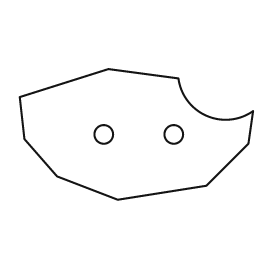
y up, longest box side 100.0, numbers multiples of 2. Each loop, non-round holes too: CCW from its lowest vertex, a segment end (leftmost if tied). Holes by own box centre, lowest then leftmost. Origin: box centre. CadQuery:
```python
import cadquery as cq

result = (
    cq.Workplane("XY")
    .moveTo(-8.0, -28.0)
    .lineTo(30.0, -22.0)
    .lineTo(48.0, -4.0)
    .lineTo(50.0, 10.0)
    .threePointArc((30.0, 8.0), (18.0, 24.0))
    .lineTo(-12.0, 28.0)
    .lineTo(-50.0, 16.0)
    .lineTo(-48.0, -2.0)
    .lineTo(-34.0, -18.0)
    .close()
    .moveTo(-14.0, 0.0)
    .circle(4.0)
    .moveTo(16.0, 0.0)
    .circle(4.0)
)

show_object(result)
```